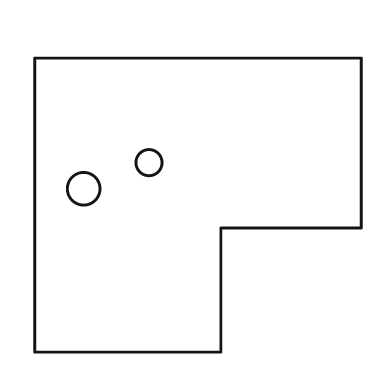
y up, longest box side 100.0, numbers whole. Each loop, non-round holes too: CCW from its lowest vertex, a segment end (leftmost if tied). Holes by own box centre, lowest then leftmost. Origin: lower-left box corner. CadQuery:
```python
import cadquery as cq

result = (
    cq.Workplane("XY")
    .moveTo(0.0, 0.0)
    .lineTo(57.0, 0.0)
    .lineTo(57.0, 38.0)
    .lineTo(100.0, 38.0)
    .lineTo(100.0, 90.0)
    .lineTo(0.0, 90.0)
    .close()
    .moveTo(15.0, 50.0)
    .circle(5.0)
    .moveTo(35.0, 58.0)
    .circle(4.0)
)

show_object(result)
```